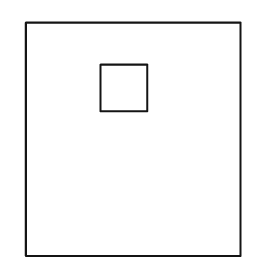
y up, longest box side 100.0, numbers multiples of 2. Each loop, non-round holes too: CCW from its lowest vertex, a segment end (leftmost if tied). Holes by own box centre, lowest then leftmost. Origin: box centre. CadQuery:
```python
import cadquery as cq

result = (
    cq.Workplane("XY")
    .moveTo(-46.0, -50.0)
    .lineTo(46.0, -50.0)
    .lineTo(46.0, 50.0)
    .lineTo(-46.0, 50.0)
    .close()
    .moveTo(-14.0, 12.0)
    .lineTo(6.0, 12.0)
    .lineTo(6.0, 32.0)
    .lineTo(-14.0, 32.0)
    .close()
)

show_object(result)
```